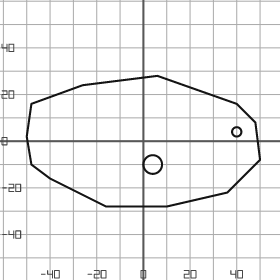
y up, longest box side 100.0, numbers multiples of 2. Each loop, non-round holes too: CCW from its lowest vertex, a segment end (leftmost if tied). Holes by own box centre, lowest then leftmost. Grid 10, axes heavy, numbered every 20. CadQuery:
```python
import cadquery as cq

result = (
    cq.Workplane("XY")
    .moveTo(-16.0, -28.0)
    .lineTo(10.0, -28.0)
    .lineTo(36.0, -22.0)
    .lineTo(50.0, -8.0)
    .lineTo(48.0, 8.0)
    .lineTo(40.0, 16.0)
    .lineTo(6.0, 28.0)
    .lineTo(-26.0, 24.0)
    .lineTo(-48.0, 16.0)
    .lineTo(-50.0, 2.0)
    .lineTo(-48.0, -10.0)
    .lineTo(-40.0, -16.0)
    .close()
    .moveTo(4.0, -10.0)
    .circle(4.0)
    .moveTo(40.0, 4.0)
    .circle(2.0)
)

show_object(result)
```